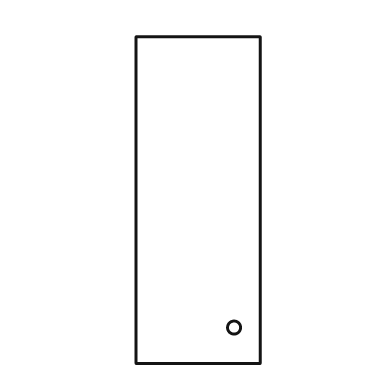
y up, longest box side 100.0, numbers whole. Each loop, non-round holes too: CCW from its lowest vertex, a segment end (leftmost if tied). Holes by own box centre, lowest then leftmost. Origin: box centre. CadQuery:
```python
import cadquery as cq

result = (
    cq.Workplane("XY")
    .moveTo(-19.0, -50.0)
    .lineTo(19.0, -50.0)
    .lineTo(19.0, 50.0)
    .lineTo(-19.0, 50.0)
    .close()
    .moveTo(11.0, -39.0)
    .circle(2.0)
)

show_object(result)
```